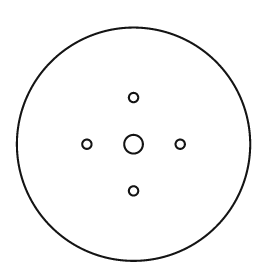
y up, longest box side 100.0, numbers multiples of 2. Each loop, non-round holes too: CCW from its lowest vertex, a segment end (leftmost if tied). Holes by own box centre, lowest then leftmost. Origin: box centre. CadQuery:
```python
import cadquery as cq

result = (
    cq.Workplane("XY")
    .moveTo(0.0, 0.0)
    .circle(50.0)
    .moveTo(0.0, -20.0)
    .circle(2.0)
    .moveTo(-20.0, 0.0)
    .circle(2.0)
    .moveTo(0.0, 0.0)
    .circle(4.0)
    .moveTo(20.0, 0.0)
    .circle(2.0)
    .moveTo(0.0, 20.0)
    .circle(2.0)
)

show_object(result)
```